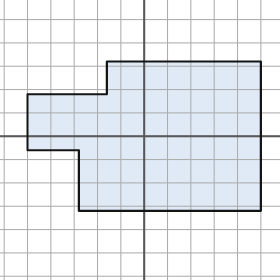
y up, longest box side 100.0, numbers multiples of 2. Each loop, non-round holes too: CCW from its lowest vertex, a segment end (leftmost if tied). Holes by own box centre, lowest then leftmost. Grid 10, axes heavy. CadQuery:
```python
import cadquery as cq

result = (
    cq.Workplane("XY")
    .moveTo(-28.0, -32.0)
    .lineTo(50.0, -32.0)
    .lineTo(50.0, 32.0)
    .lineTo(-16.0, 32.0)
    .lineTo(-16.0, 18.0)
    .lineTo(-50.0, 18.0)
    .lineTo(-50.0, -6.0)
    .lineTo(-28.0, -6.0)
    .close()
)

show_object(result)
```